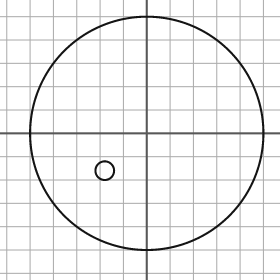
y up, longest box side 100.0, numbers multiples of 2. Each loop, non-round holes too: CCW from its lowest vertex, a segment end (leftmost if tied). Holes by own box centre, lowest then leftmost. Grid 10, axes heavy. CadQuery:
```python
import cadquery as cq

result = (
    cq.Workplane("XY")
    .moveTo(0.0, 0.0)
    .circle(50.0)
    .moveTo(-18.0, -16.0)
    .circle(4.0)
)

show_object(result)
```